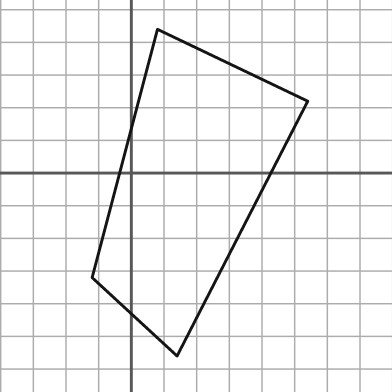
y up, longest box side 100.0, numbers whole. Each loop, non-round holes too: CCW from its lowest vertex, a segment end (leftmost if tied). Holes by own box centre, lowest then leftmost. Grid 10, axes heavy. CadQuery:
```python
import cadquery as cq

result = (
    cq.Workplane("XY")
    .moveTo(14.0, -56.0)
    .lineTo(54.0, 22.0)
    .lineTo(8.0, 44.0)
    .lineTo(-12.0, -32.0)
    .close()
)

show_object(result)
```